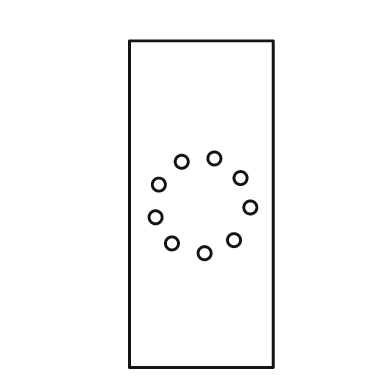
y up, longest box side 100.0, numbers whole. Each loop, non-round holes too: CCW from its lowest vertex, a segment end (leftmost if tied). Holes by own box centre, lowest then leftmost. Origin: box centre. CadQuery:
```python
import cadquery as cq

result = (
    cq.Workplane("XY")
    .moveTo(-22.0, -50.0)
    .lineTo(22.0, -50.0)
    .lineTo(22.0, 50.0)
    .lineTo(-22.0, 50.0)
    .close()
    .moveTo(1.0, -15.0)
    .circle(2.0)
    .moveTo(-9.0, -12.0)
    .circle(2.0)
    .moveTo(10.0, -11.0)
    .circle(2.0)
    .moveTo(-14.0, -4.0)
    .circle(2.0)
    .moveTo(15.0, -1.0)
    .circle(2.0)
    .moveTo(-13.0, 6.0)
    .circle(2.0)
    .moveTo(12.0, 8.0)
    .circle(2.0)
    .moveTo(-6.0, 13.0)
    .circle(2.0)
    .moveTo(4.0, 14.0)
    .circle(2.0)
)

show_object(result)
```